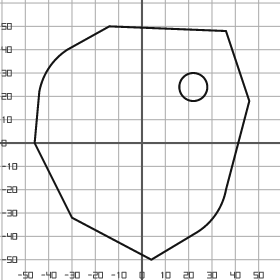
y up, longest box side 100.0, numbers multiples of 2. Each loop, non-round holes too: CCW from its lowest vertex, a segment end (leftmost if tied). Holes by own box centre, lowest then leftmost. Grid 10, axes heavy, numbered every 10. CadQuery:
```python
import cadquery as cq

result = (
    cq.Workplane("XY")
    .moveTo(4.0, -50.0)
    .lineTo(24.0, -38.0)
    .threePointArc((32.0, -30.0), (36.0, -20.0))
    .lineTo(46.0, 18.0)
    .lineTo(36.0, 48.0)
    .lineTo(-14.0, 50.0)
    .lineTo(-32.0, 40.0)
    .threePointArc((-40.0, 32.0), (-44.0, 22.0))
    .lineTo(-46.0, 0.0)
    .lineTo(-30.0, -32.0)
    .close()
    .moveTo(22.0, 24.0)
    .circle(6.0)
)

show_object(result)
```